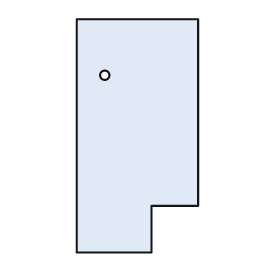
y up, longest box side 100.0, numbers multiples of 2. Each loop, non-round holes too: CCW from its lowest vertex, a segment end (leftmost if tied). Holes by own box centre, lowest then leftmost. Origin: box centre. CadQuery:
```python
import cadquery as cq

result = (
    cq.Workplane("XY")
    .moveTo(-26.0, -50.0)
    .lineTo(6.0, -50.0)
    .lineTo(6.0, -30.0)
    .lineTo(26.0, -30.0)
    .lineTo(26.0, 50.0)
    .lineTo(-26.0, 50.0)
    .close()
    .moveTo(-14.0, 26.0)
    .circle(2.0)
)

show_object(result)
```